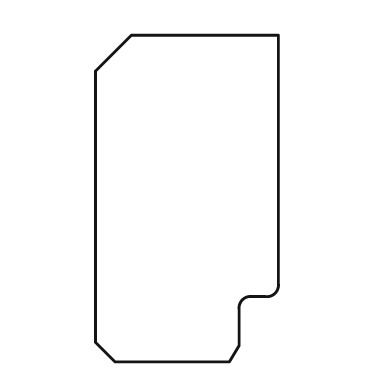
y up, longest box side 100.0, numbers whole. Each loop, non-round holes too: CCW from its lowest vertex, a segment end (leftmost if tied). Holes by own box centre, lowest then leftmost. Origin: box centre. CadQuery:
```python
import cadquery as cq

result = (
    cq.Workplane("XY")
    .moveTo(-22.0, -50.0)
    .lineTo(13.0, -50.0)
    .lineTo(16.0, -45.0)
    .lineTo(16.0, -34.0)
    .threePointArc((17.0, -31.0), (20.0, -30.0))
    .lineTo(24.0, -30.0)
    .threePointArc((27.0, -29.0), (28.0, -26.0))
    .lineTo(28.0, 50.0)
    .lineTo(-17.0, 50.0)
    .lineTo(-28.0, 39.0)
    .lineTo(-28.0, -44.0)
    .close()
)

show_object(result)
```